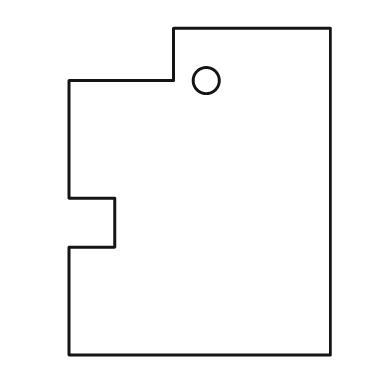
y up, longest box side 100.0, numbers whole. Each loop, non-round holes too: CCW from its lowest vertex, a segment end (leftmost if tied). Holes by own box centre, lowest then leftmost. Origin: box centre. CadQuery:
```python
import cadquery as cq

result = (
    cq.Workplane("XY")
    .moveTo(-40.0, -50.0)
    .lineTo(40.0, -50.0)
    .lineTo(40.0, 50.0)
    .lineTo(-8.0, 50.0)
    .lineTo(-8.0, 34.0)
    .lineTo(-40.0, 34.0)
    .lineTo(-40.0, -2.0)
    .lineTo(-26.0, -2.0)
    .lineTo(-26.0, -17.0)
    .lineTo(-40.0, -17.0)
    .close()
    .moveTo(2.0, 34.0)
    .circle(4.0)
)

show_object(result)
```